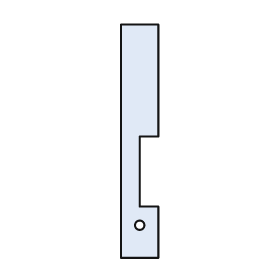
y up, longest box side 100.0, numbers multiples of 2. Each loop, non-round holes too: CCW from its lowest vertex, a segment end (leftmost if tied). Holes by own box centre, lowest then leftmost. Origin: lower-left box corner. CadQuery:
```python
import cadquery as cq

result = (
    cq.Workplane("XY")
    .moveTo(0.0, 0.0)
    .lineTo(16.0, 0.0)
    .lineTo(16.0, 22.0)
    .lineTo(8.0, 22.0)
    .lineTo(8.0, 52.0)
    .lineTo(16.0, 52.0)
    .lineTo(16.0, 100.0)
    .lineTo(0.0, 100.0)
    .close()
    .moveTo(8.0, 14.0)
    .circle(2.0)
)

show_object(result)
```